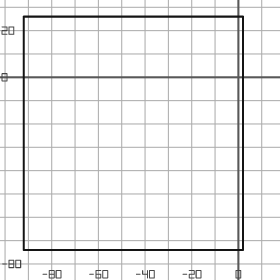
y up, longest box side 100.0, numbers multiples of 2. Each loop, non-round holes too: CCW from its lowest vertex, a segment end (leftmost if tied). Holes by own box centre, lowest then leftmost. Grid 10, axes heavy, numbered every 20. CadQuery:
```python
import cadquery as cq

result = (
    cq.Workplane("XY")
    .moveTo(-92.0, -74.0)
    .lineTo(2.0, -74.0)
    .lineTo(2.0, 26.0)
    .lineTo(-92.0, 26.0)
    .close()
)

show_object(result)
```